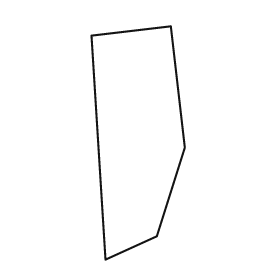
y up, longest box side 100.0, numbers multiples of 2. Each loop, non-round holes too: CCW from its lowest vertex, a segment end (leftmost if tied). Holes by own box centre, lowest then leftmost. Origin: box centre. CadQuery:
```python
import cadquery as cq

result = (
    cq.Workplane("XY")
    .moveTo(-14.0, -50.0)
    .lineTo(8.0, -40.0)
    .lineTo(20.0, -2.0)
    .lineTo(14.0, 50.0)
    .lineTo(-20.0, 46.0)
    .close()
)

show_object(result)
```